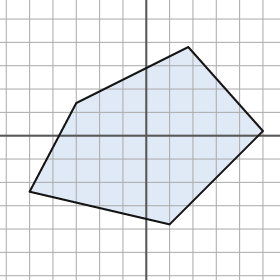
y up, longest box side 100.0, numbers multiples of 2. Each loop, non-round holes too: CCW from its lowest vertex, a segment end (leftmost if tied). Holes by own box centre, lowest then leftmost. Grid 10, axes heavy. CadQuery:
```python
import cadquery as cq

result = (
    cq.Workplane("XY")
    .moveTo(10.0, -38.0)
    .lineTo(50.0, 2.0)
    .lineTo(18.0, 38.0)
    .lineTo(-30.0, 14.0)
    .lineTo(-50.0, -24.0)
    .close()
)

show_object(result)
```